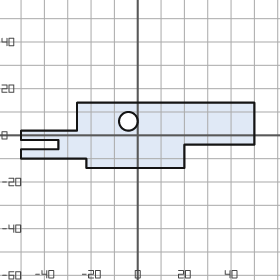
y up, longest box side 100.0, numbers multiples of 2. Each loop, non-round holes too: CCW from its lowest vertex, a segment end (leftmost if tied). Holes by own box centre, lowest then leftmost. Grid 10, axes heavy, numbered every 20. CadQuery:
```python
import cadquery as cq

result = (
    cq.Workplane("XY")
    .moveTo(-22.0, -14.0)
    .lineTo(20.0, -14.0)
    .lineTo(20.0, -4.0)
    .lineTo(50.0, -4.0)
    .lineTo(50.0, 14.0)
    .lineTo(-26.0, 14.0)
    .lineTo(-26.0, 2.0)
    .lineTo(-50.0, 2.0)
    .lineTo(-50.0, -2.0)
    .lineTo(-34.0, -2.0)
    .lineTo(-34.0, -6.0)
    .lineTo(-50.0, -6.0)
    .lineTo(-50.0, -10.0)
    .lineTo(-22.0, -10.0)
    .close()
    .moveTo(-4.0, 6.0)
    .circle(4.0)
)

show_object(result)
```